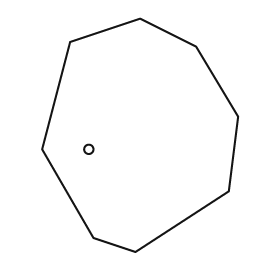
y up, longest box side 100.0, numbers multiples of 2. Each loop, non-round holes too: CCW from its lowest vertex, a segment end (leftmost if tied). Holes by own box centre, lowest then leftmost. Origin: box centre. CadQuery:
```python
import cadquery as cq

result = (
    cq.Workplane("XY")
    .moveTo(-2.0, -50.0)
    .lineTo(38.0, -24.0)
    .lineTo(42.0, 8.0)
    .lineTo(24.0, 38.0)
    .lineTo(0.0, 50.0)
    .lineTo(-30.0, 40.0)
    .lineTo(-42.0, -6.0)
    .lineTo(-20.0, -44.0)
    .close()
    .moveTo(-22.0, -6.0)
    .circle(2.0)
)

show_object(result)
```